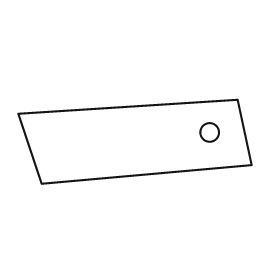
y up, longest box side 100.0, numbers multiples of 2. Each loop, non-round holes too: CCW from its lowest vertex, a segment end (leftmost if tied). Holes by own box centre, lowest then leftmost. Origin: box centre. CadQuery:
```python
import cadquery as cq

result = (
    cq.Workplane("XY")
    .moveTo(-40.0, -18.0)
    .lineTo(50.0, -10.0)
    .lineTo(44.0, 18.0)
    .lineTo(-50.0, 12.0)
    .close()
    .moveTo(32.0, 4.0)
    .circle(4.0)
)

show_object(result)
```